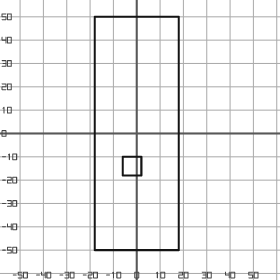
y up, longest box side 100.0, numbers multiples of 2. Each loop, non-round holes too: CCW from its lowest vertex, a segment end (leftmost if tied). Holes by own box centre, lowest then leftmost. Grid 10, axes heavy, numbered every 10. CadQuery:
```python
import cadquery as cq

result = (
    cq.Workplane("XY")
    .moveTo(-18.0, -50.0)
    .lineTo(18.0, -50.0)
    .lineTo(18.0, 50.0)
    .lineTo(-18.0, 50.0)
    .close()
    .moveTo(-6.0, -18.0)
    .lineTo(2.0, -18.0)
    .lineTo(2.0, -10.0)
    .lineTo(-6.0, -10.0)
    .close()
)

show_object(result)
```